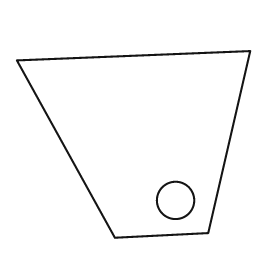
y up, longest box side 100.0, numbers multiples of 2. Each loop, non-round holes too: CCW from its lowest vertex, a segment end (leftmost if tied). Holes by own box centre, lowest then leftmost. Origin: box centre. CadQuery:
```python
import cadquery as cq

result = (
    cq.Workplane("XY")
    .moveTo(-8.0, -40.0)
    .lineTo(32.0, -38.0)
    .lineTo(50.0, 40.0)
    .lineTo(-50.0, 36.0)
    .close()
    .moveTo(18.0, -24.0)
    .circle(8.0)
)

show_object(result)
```